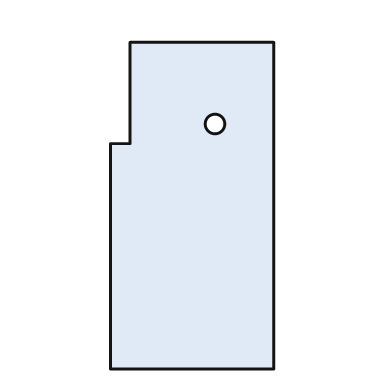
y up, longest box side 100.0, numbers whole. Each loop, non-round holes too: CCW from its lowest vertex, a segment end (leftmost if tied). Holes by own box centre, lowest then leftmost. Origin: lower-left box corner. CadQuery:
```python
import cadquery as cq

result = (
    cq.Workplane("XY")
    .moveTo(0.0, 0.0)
    .lineTo(50.0, 0.0)
    .lineTo(50.0, 100.0)
    .lineTo(6.0, 100.0)
    .lineTo(6.0, 69.0)
    .lineTo(0.0, 69.0)
    .close()
    .moveTo(32.0, 75.0)
    .circle(3.0)
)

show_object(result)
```